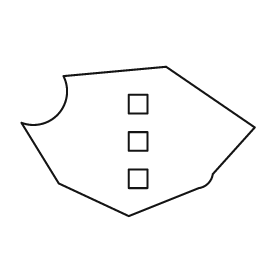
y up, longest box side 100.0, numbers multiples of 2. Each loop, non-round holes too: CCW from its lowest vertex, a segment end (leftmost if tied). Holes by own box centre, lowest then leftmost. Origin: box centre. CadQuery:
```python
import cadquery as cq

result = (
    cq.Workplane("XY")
    .moveTo(-4.0, -32.0)
    .lineTo(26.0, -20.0)
    .threePointArc((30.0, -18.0), (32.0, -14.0))
    .lineTo(50.0, 6.0)
    .lineTo(12.0, 32.0)
    .lineTo(-32.0, 28.0)
    .threePointArc((-34.0, 12.0), (-50.0, 8.0))
    .lineTo(-34.0, -18.0)
    .close()
    .moveTo(-4.0, -20.0)
    .lineTo(4.0, -20.0)
    .lineTo(4.0, -12.0)
    .lineTo(-4.0, -12.0)
    .close()
    .moveTo(-4.0, -4.0)
    .lineTo(4.0, -4.0)
    .lineTo(4.0, 4.0)
    .lineTo(-4.0, 4.0)
    .close()
    .moveTo(-4.0, 12.0)
    .lineTo(4.0, 12.0)
    .lineTo(4.0, 20.0)
    .lineTo(-4.0, 20.0)
    .close()
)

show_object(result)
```